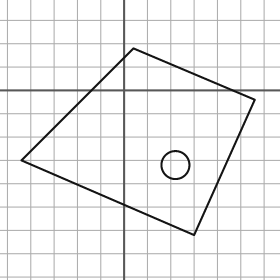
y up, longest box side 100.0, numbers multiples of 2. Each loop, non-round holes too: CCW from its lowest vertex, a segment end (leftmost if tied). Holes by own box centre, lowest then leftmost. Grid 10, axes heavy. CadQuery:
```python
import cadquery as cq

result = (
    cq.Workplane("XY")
    .moveTo(30.0, -62.0)
    .lineTo(56.0, -4.0)
    .lineTo(4.0, 18.0)
    .lineTo(-44.0, -30.0)
    .close()
    .moveTo(22.0, -32.0)
    .circle(6.0)
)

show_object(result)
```